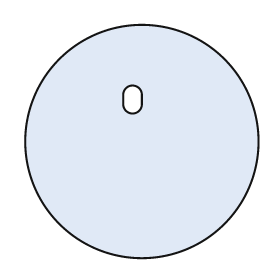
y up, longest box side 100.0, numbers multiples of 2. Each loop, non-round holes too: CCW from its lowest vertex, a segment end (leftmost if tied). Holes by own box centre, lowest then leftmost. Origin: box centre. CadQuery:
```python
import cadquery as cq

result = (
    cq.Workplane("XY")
    .moveTo(0.0, 0.0)
    .circle(50.0)
    .moveTo(-8.0, 16.0)
    .threePointArc((-4.0, 12.0), (0.0, 16.0))
    .lineTo(0.0, 20.0)
    .threePointArc((-4.0, 24.0), (-8.0, 20.0))
    .close()
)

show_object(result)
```